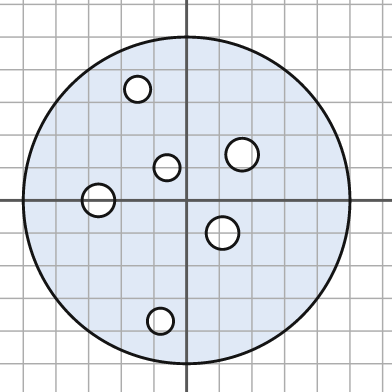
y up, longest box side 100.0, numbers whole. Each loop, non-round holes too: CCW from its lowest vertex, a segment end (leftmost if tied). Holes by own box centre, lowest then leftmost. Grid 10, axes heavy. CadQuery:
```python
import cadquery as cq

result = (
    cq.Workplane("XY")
    .moveTo(0.0, 0.0)
    .circle(50.0)
    .moveTo(-8.0, -37.0)
    .circle(4.0)
    .moveTo(11.0, -10.0)
    .circle(5.0)
    .moveTo(-27.0, 0.0)
    .circle(5.0)
    .moveTo(-6.0, 10.0)
    .circle(4.0)
    .moveTo(17.0, 14.0)
    .circle(5.0)
    .moveTo(-15.0, 34.0)
    .circle(4.0)
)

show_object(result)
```